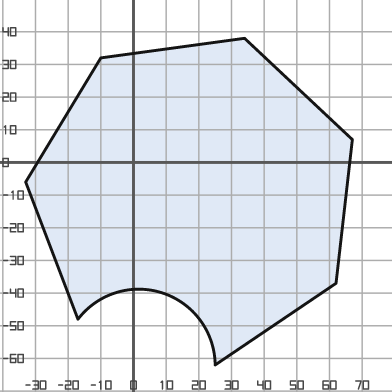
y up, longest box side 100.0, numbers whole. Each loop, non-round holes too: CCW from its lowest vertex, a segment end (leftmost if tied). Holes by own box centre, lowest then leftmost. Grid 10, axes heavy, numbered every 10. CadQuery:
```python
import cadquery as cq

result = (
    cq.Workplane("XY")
    .moveTo(25.0, -62.0)
    .lineTo(62.0, -37.0)
    .lineTo(67.0, 7.0)
    .lineTo(34.0, 38.0)
    .lineTo(-10.0, 32.0)
    .lineTo(-33.0, -6.0)
    .lineTo(-17.0, -48.0)
    .threePointArc((9.0, -40.0), (25.0, -62.0))
    .close()
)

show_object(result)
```